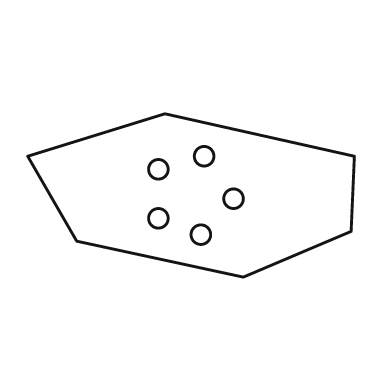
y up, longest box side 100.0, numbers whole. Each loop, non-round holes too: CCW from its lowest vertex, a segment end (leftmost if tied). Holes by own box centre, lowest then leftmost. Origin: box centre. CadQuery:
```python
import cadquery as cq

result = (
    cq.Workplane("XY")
    .moveTo(16.0, -25.0)
    .lineTo(49.0, -11.0)
    .lineTo(50.0, 12.0)
    .lineTo(-8.0, 25.0)
    .lineTo(-50.0, 12.0)
    .lineTo(-35.0, -14.0)
    .close()
    .moveTo(3.0, -12.0)
    .circle(3.0)
    .moveTo(-10.0, -7.0)
    .circle(3.0)
    .moveTo(13.0, -1.0)
    .circle(3.0)
    .moveTo(-10.0, 8.0)
    .circle(3.0)
    .moveTo(4.0, 12.0)
    .circle(3.0)
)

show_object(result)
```